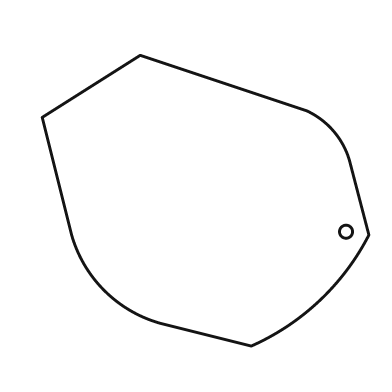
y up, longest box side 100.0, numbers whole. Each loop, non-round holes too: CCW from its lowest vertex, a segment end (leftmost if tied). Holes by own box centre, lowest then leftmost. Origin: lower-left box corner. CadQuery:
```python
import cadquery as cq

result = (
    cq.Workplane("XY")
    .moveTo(64.0, 0.0)
    .threePointArc((85.0, 14.0), (100.0, 34.0))
    .lineTo(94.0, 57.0)
    .threePointArc((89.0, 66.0), (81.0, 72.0))
    .lineTo(30.0, 89.0)
    .lineTo(0.0, 70.0)
    .lineTo(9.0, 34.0)
    .threePointArc((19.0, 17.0), (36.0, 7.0))
    .close()
    .moveTo(93.0, 35.0)
    .circle(2.0)
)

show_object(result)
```